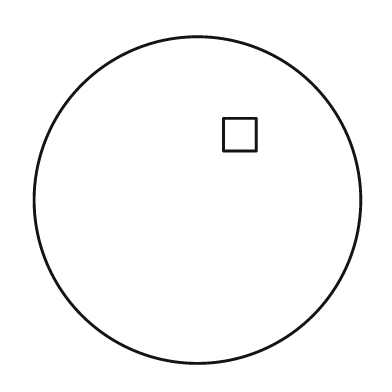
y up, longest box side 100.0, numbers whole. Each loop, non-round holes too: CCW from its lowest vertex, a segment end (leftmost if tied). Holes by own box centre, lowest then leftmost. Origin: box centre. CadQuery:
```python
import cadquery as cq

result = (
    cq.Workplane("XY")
    .moveTo(0.0, 0.0)
    .circle(50.0)
    .moveTo(8.0, 15.0)
    .lineTo(18.0, 15.0)
    .lineTo(18.0, 25.0)
    .lineTo(8.0, 25.0)
    .close()
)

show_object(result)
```